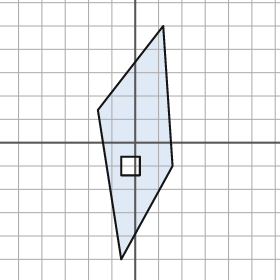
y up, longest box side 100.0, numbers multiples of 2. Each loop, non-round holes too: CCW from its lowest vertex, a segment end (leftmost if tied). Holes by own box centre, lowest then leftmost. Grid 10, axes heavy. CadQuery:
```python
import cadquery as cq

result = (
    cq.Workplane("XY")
    .moveTo(-6.0, -50.0)
    .lineTo(16.0, -10.0)
    .lineTo(12.0, 50.0)
    .lineTo(-16.0, 14.0)
    .close()
    .moveTo(-6.0, -14.0)
    .lineTo(2.0, -14.0)
    .lineTo(2.0, -6.0)
    .lineTo(-6.0, -6.0)
    .close()
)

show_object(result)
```